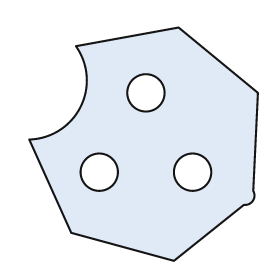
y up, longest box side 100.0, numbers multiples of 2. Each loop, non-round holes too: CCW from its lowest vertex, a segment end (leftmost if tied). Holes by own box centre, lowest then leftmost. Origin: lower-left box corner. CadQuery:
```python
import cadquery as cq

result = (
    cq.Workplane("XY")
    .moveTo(62.0, 0.0)
    .lineTo(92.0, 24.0)
    .threePointArc((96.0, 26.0), (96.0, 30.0))
    .lineTo(98.0, 72.0)
    .lineTo(64.0, 100.0)
    .lineTo(20.0, 92.0)
    .threePointArc((22.0, 66.0), (0.0, 52.0))
    .lineTo(18.0, 12.0)
    .close()
    .moveTo(30.0, 38.0)
    .circle(8.0)
    .moveTo(70.0, 38.0)
    .circle(8.0)
    .moveTo(50.0, 72.0)
    .circle(8.0)
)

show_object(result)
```